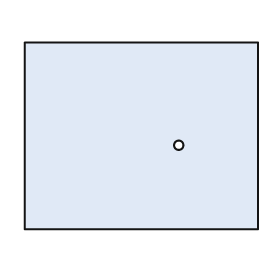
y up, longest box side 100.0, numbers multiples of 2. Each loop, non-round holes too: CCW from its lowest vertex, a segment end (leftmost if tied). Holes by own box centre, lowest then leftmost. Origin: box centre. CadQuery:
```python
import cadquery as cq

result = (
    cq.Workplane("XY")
    .moveTo(-50.0, -40.0)
    .lineTo(50.0, -40.0)
    .lineTo(50.0, 40.0)
    .lineTo(-50.0, 40.0)
    .close()
    .moveTo(16.0, -4.0)
    .circle(2.0)
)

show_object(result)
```